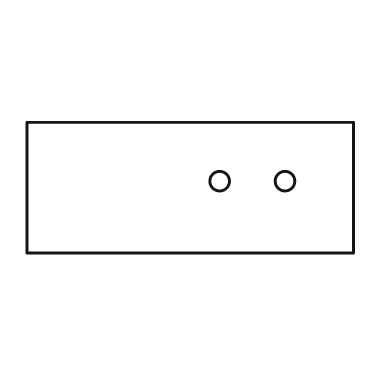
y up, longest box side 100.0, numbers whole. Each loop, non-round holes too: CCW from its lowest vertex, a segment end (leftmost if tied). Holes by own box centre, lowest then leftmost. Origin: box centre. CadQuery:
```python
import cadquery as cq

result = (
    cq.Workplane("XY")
    .moveTo(-50.0, -20.0)
    .lineTo(50.0, -20.0)
    .lineTo(50.0, 20.0)
    .lineTo(-50.0, 20.0)
    .close()
    .moveTo(9.0, 2.0)
    .circle(3.0)
    .moveTo(29.0, 2.0)
    .circle(3.0)
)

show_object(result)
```